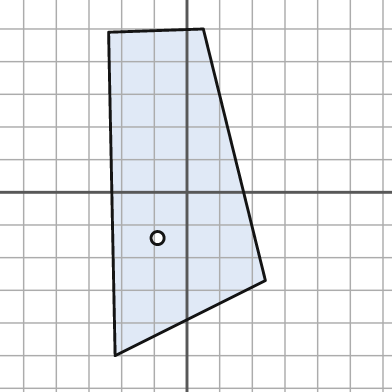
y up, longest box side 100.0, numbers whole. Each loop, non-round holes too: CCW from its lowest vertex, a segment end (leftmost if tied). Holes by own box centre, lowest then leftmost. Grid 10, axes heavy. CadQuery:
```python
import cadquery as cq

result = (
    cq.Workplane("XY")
    .moveTo(-22.0, -50.0)
    .lineTo(24.0, -27.0)
    .lineTo(5.0, 50.0)
    .lineTo(-24.0, 49.0)
    .close()
    .moveTo(-9.0, -14.0)
    .circle(2.0)
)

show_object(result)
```